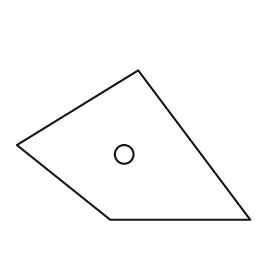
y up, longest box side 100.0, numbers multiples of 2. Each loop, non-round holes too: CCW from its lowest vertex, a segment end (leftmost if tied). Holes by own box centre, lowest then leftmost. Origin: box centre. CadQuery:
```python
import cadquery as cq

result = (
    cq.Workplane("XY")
    .moveTo(-10.0, -32.0)
    .lineTo(50.0, -32.0)
    .lineTo(2.0, 32.0)
    .lineTo(-50.0, 0.0)
    .close()
    .moveTo(-4.0, -4.0)
    .circle(4.0)
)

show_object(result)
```